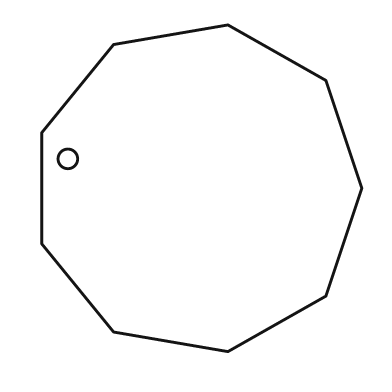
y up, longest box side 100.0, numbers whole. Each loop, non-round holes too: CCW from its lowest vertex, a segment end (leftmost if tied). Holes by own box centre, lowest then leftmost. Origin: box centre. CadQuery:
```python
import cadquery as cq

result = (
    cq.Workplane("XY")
    .moveTo(8.0, -50.0)
    .lineTo(38.0, -33.0)
    .lineTo(49.0, 0.0)
    .lineTo(38.0, 33.0)
    .lineTo(8.0, 50.0)
    .lineTo(-27.0, 44.0)
    .lineTo(-49.0, 17.0)
    .lineTo(-49.0, -17.0)
    .lineTo(-27.0, -44.0)
    .close()
    .moveTo(-41.0, 9.0)
    .circle(3.0)
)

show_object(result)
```